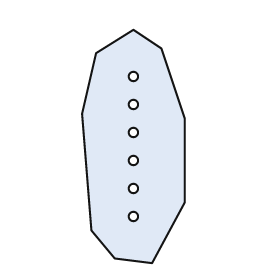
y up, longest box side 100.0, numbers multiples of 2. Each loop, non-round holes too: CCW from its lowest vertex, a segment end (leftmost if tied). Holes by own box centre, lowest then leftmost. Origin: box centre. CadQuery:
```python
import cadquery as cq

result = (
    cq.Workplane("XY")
    .moveTo(8.0, -50.0)
    .lineTo(22.0, -24.0)
    .lineTo(22.0, 12.0)
    .lineTo(12.0, 42.0)
    .lineTo(0.0, 50.0)
    .lineTo(-16.0, 40.0)
    .lineTo(-22.0, 14.0)
    .lineTo(-18.0, -36.0)
    .lineTo(-8.0, -48.0)
    .close()
    .moveTo(0.0, -30.0)
    .circle(2.0)
    .moveTo(0.0, -18.0)
    .circle(2.0)
    .moveTo(0.0, -6.0)
    .circle(2.0)
    .moveTo(0.0, 6.0)
    .circle(2.0)
    .moveTo(0.0, 18.0)
    .circle(2.0)
    .moveTo(0.0, 30.0)
    .circle(2.0)
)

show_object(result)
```